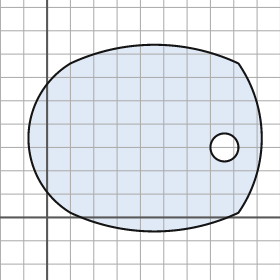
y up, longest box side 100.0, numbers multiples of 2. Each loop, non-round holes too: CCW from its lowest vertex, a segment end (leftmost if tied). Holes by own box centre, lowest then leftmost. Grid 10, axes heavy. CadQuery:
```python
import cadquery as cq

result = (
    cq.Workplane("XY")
    .moveTo(10.0, 2.0)
    .threePointArc((46.0, -6.0), (82.0, 2.0))
    .threePointArc((92.0, 34.0), (82.0, 66.0))
    .threePointArc((46.0, 74.0), (10.0, 66.0))
    .threePointArc((-8.0, 34.0), (10.0, 2.0))
    .close()
    .moveTo(76.0, 30.0)
    .circle(6.0)
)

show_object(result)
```